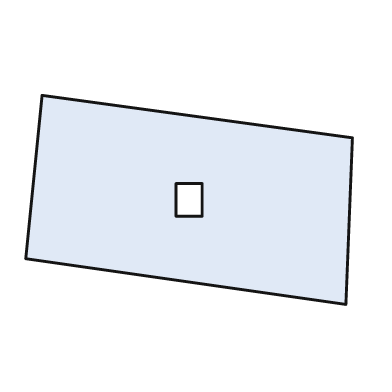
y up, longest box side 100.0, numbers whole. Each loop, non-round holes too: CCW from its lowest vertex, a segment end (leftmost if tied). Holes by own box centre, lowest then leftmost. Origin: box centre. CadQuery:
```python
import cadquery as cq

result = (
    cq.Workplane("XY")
    .moveTo(48.0, -32.0)
    .lineTo(50.0, 19.0)
    .lineTo(-45.0, 32.0)
    .lineTo(-50.0, -18.0)
    .close()
    .moveTo(-4.0, -5.0)
    .lineTo(4.0, -5.0)
    .lineTo(4.0, 5.0)
    .lineTo(-4.0, 5.0)
    .close()
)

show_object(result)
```